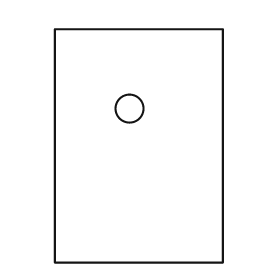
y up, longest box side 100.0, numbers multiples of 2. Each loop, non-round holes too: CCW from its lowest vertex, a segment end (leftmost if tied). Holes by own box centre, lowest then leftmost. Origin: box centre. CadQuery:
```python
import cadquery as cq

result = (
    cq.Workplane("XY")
    .moveTo(-36.0, -50.0)
    .lineTo(36.0, -50.0)
    .lineTo(36.0, 50.0)
    .lineTo(-36.0, 50.0)
    .close()
    .moveTo(-4.0, 16.0)
    .circle(6.0)
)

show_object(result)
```